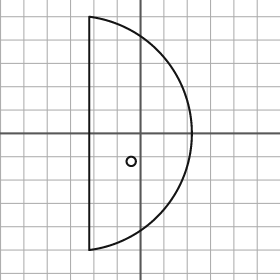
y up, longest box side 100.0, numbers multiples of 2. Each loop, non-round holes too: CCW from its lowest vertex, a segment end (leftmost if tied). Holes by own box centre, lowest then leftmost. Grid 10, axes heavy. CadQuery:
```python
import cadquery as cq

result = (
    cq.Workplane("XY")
    .moveTo(-22.0, -50.0)
    .threePointArc((22.0, 0.0), (-22.0, 50.0))
    .close()
    .moveTo(-4.0, -12.0)
    .circle(2.0)
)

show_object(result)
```